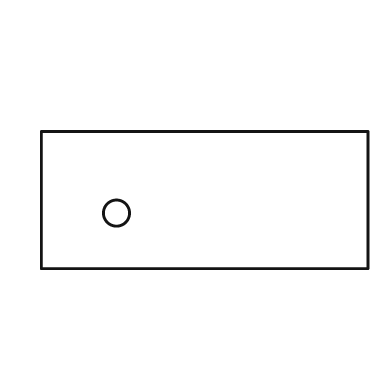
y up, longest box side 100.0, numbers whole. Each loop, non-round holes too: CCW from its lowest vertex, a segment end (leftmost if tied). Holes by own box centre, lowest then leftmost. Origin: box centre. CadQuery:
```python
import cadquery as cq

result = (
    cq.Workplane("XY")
    .moveTo(-50.0, -21.0)
    .lineTo(50.0, -21.0)
    .lineTo(50.0, 21.0)
    .lineTo(-50.0, 21.0)
    .close()
    .moveTo(-27.0, -4.0)
    .circle(4.0)
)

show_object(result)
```